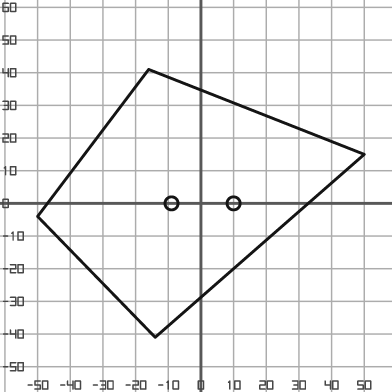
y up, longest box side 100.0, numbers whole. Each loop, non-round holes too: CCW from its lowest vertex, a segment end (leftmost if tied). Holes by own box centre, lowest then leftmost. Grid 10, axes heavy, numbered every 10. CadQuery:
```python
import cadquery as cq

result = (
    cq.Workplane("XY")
    .moveTo(-14.0, -41.0)
    .lineTo(50.0, 15.0)
    .lineTo(-16.0, 41.0)
    .lineTo(-50.0, -4.0)
    .close()
    .moveTo(-9.0, 0.0)
    .circle(2.0)
    .moveTo(10.0, 0.0)
    .circle(2.0)
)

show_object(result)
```